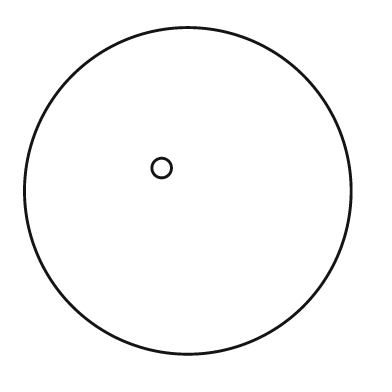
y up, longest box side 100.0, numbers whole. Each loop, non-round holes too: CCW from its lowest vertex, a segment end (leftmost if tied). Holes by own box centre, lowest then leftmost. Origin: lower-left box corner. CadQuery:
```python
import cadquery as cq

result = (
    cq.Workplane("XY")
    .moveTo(50.0, 50.0)
    .circle(50.0)
    .moveTo(42.0, 57.0)
    .circle(3.0)
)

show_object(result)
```